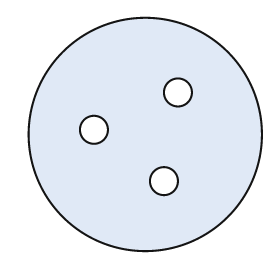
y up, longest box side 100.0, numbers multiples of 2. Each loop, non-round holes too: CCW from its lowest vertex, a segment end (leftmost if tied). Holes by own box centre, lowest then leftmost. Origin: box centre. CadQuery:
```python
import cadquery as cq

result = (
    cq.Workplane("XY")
    .moveTo(0.0, 0.0)
    .circle(50.0)
    .moveTo(8.0, -20.0)
    .circle(6.0)
    .moveTo(-22.0, 2.0)
    .circle(6.0)
    .moveTo(14.0, 18.0)
    .circle(6.0)
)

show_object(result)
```